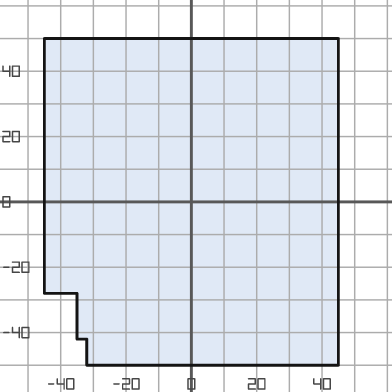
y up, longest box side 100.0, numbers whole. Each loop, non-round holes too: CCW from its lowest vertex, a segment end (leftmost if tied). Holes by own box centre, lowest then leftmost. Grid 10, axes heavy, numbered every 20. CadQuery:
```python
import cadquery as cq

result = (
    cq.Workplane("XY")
    .moveTo(-32.0, -50.0)
    .lineTo(45.0, -50.0)
    .lineTo(45.0, 50.0)
    .lineTo(-45.0, 50.0)
    .lineTo(-45.0, -28.0)
    .lineTo(-35.0, -28.0)
    .lineTo(-35.0, -42.0)
    .lineTo(-32.0, -42.0)
    .close()
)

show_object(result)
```